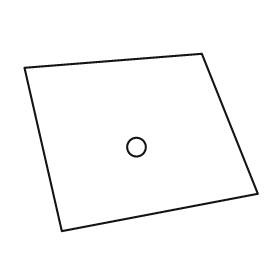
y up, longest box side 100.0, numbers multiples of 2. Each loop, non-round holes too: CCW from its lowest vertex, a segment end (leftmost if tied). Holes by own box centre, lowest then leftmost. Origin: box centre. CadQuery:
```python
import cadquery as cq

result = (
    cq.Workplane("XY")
    .moveTo(-34.0, -38.0)
    .lineTo(50.0, -22.0)
    .lineTo(26.0, 38.0)
    .lineTo(-50.0, 32.0)
    .close()
    .moveTo(-2.0, -2.0)
    .circle(4.0)
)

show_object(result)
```